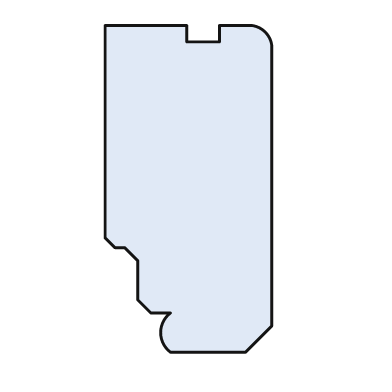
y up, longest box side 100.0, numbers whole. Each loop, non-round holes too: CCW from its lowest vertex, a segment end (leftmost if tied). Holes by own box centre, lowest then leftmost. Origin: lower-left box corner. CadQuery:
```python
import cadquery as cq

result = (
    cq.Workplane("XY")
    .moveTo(20.0, 0.0)
    .lineTo(43.0, 0.0)
    .lineTo(51.0, 8.0)
    .lineTo(51.0, 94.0)
    .threePointArc((49.0, 98.0), (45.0, 100.0))
    .lineTo(35.0, 100.0)
    .lineTo(35.0, 95.0)
    .lineTo(25.0, 95.0)
    .lineTo(25.0, 100.0)
    .lineTo(0.0, 100.0)
    .lineTo(0.0, 35.0)
    .lineTo(3.0, 32.0)
    .lineTo(6.0, 32.0)
    .lineTo(10.0, 28.0)
    .lineTo(10.0, 16.0)
    .lineTo(14.0, 12.0)
    .lineTo(20.0, 12.0)
    .threePointArc((17.0, 6.0), (20.0, 0.0))
    .close()
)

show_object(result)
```